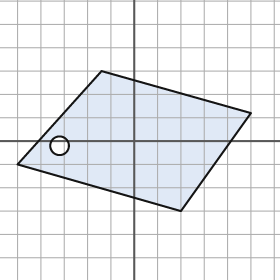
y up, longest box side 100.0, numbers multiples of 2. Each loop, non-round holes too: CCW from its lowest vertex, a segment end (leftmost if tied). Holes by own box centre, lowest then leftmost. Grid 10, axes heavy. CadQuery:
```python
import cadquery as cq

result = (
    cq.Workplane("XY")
    .moveTo(20.0, -30.0)
    .lineTo(50.0, 12.0)
    .lineTo(-14.0, 30.0)
    .lineTo(-50.0, -10.0)
    .close()
    .moveTo(-32.0, -2.0)
    .circle(4.0)
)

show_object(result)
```